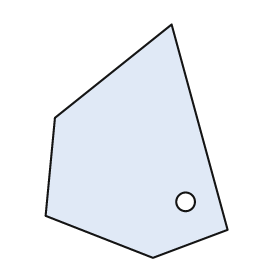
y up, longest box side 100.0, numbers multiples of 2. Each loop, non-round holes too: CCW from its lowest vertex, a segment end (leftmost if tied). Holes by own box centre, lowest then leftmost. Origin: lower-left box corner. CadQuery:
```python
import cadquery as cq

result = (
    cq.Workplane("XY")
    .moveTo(46.0, 0.0)
    .lineTo(78.0, 12.0)
    .lineTo(54.0, 100.0)
    .lineTo(4.0, 60.0)
    .lineTo(0.0, 18.0)
    .close()
    .moveTo(60.0, 24.0)
    .circle(4.0)
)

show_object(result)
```